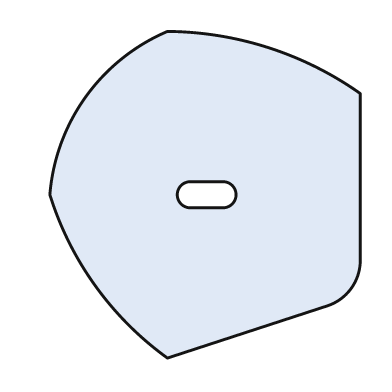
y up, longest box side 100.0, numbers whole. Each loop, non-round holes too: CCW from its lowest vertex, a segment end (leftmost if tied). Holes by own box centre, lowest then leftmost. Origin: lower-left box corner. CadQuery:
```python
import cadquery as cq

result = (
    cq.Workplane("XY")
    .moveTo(36.0, 0.0)
    .lineTo(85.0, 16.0)
    .threePointArc((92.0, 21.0), (95.0, 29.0))
    .lineTo(95.0, 81.0)
    .threePointArc((67.0, 95.0), (36.0, 100.0))
    .threePointArc((11.0, 80.0), (0.0, 50.0))
    .threePointArc((14.0, 22.0), (36.0, 0.0))
    .close()
    .moveTo(43.0, 46.0)
    .lineTo(53.0, 46.0)
    .threePointArc((57.0, 50.0), (53.0, 54.0))
    .lineTo(43.0, 54.0)
    .threePointArc((39.0, 50.0), (43.0, 46.0))
    .close()
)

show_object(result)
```